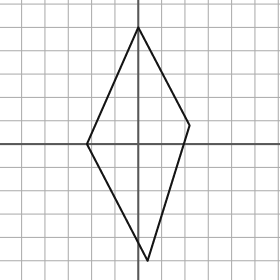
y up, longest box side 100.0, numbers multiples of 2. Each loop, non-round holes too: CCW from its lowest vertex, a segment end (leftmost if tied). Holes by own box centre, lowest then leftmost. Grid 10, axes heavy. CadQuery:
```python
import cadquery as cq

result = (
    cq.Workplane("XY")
    .moveTo(4.0, -50.0)
    .lineTo(22.0, 8.0)
    .lineTo(0.0, 50.0)
    .lineTo(-22.0, 0.0)
    .close()
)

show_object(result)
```